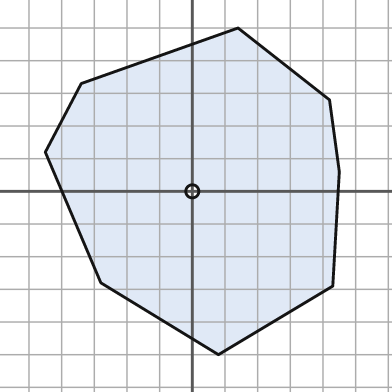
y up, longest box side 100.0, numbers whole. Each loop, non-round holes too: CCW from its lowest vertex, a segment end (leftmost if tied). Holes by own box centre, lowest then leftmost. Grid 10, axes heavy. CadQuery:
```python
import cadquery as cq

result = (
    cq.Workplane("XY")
    .moveTo(8.0, -50.0)
    .lineTo(43.0, -29.0)
    .lineTo(45.0, 6.0)
    .lineTo(42.0, 28.0)
    .lineTo(14.0, 50.0)
    .lineTo(-34.0, 33.0)
    .lineTo(-45.0, 12.0)
    .lineTo(-28.0, -28.0)
    .close()
    .moveTo(0.0, 0.0)
    .circle(2.0)
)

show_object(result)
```